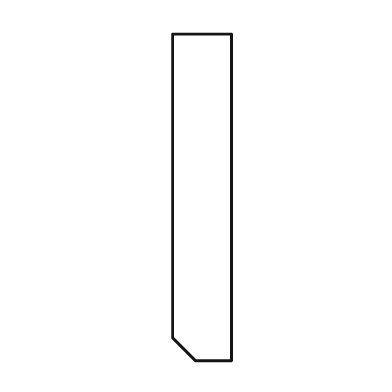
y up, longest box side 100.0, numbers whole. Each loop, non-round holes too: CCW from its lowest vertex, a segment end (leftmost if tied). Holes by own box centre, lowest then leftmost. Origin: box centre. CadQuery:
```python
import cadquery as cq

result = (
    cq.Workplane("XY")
    .moveTo(-2.0, -50.0)
    .lineTo(9.0, -50.0)
    .lineTo(9.0, 50.0)
    .lineTo(-9.0, 50.0)
    .lineTo(-9.0, -43.0)
    .close()
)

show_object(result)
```